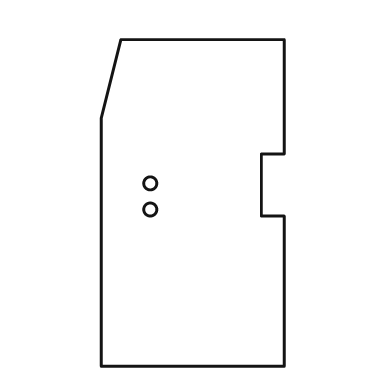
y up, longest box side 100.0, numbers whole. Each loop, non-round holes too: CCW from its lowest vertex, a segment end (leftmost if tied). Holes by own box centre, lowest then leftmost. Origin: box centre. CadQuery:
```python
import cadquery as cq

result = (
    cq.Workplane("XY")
    .moveTo(-28.0, -50.0)
    .lineTo(28.0, -50.0)
    .lineTo(28.0, -4.0)
    .lineTo(21.0, -4.0)
    .lineTo(21.0, 15.0)
    .lineTo(28.0, 15.0)
    .lineTo(28.0, 50.0)
    .lineTo(-22.0, 50.0)
    .lineTo(-28.0, 26.0)
    .close()
    .moveTo(-13.0, -2.0)
    .circle(2.0)
    .moveTo(-13.0, 6.0)
    .circle(2.0)
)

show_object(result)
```